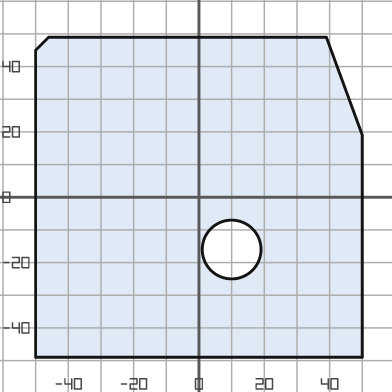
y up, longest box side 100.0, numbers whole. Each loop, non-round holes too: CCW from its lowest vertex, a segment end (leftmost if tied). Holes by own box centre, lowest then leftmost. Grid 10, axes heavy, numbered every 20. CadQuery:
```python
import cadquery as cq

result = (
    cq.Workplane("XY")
    .moveTo(-50.0, -49.0)
    .lineTo(50.0, -49.0)
    .lineTo(50.0, 19.0)
    .lineTo(39.0, 49.0)
    .lineTo(-46.0, 49.0)
    .lineTo(-50.0, 45.0)
    .close()
    .moveTo(10.0, -16.0)
    .circle(9.0)
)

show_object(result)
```